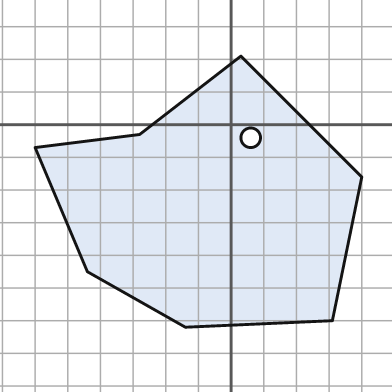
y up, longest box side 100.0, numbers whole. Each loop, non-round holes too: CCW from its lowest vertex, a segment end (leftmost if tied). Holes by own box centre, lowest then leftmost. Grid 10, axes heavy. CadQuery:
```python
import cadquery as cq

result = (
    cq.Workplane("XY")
    .moveTo(-14.0, -62.0)
    .lineTo(31.0, -60.0)
    .lineTo(40.0, -16.0)
    .lineTo(3.0, 21.0)
    .lineTo(-28.0, -3.0)
    .lineTo(-60.0, -7.0)
    .lineTo(-44.0, -45.0)
    .close()
    .moveTo(6.0, -4.0)
    .circle(3.0)
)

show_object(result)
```